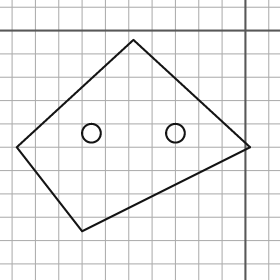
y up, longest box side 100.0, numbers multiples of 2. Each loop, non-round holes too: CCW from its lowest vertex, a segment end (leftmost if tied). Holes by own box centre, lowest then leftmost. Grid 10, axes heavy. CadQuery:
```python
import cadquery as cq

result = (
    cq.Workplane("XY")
    .moveTo(-70.0, -86.0)
    .lineTo(2.0, -50.0)
    .lineTo(-48.0, -4.0)
    .lineTo(-98.0, -50.0)
    .close()
    .moveTo(-66.0, -44.0)
    .circle(4.0)
    .moveTo(-30.0, -44.0)
    .circle(4.0)
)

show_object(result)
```